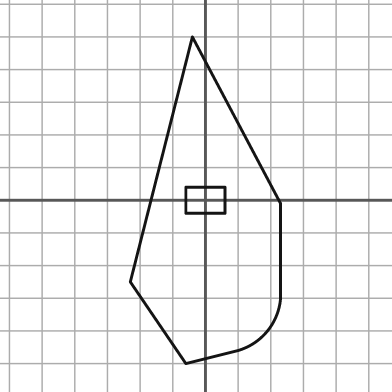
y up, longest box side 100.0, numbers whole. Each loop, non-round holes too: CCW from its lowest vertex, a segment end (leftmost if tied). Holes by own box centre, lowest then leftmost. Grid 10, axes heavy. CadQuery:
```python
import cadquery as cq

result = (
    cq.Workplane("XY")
    .moveTo(-6.0, -50.0)
    .lineTo(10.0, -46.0)
    .threePointArc((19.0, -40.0), (23.0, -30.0))
    .lineTo(23.0, -1.0)
    .lineTo(-4.0, 50.0)
    .lineTo(-23.0, -25.0)
    .close()
    .moveTo(-6.0, -4.0)
    .lineTo(6.0, -4.0)
    .lineTo(6.0, 4.0)
    .lineTo(-6.0, 4.0)
    .close()
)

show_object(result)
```